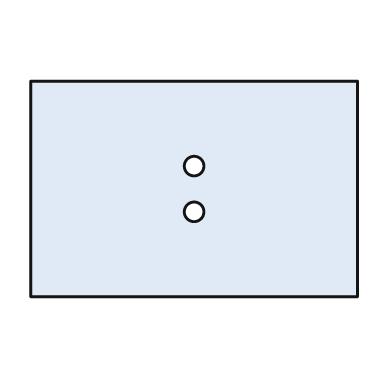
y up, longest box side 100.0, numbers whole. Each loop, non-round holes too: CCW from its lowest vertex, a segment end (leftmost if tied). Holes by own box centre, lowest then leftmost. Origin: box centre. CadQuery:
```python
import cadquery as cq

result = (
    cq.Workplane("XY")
    .moveTo(-50.0, -33.0)
    .lineTo(50.0, -33.0)
    .lineTo(50.0, 33.0)
    .lineTo(-50.0, 33.0)
    .close()
    .moveTo(0.0, -7.0)
    .circle(3.0)
    .moveTo(0.0, 7.0)
    .circle(3.0)
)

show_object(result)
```